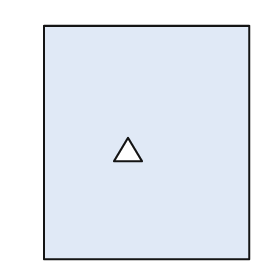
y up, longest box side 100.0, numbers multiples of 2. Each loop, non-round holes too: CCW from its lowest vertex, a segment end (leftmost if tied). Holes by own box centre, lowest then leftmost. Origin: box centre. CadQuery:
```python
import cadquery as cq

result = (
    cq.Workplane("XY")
    .moveTo(-44.0, -50.0)
    .lineTo(44.0, -50.0)
    .lineTo(44.0, 50.0)
    .lineTo(-44.0, 50.0)
    .close()
    .moveTo(-14.0, -8.0)
    .lineTo(-2.0, -8.0)
    .lineTo(-8.0, 2.0)
    .close()
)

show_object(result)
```